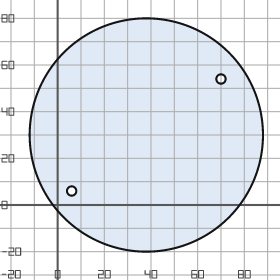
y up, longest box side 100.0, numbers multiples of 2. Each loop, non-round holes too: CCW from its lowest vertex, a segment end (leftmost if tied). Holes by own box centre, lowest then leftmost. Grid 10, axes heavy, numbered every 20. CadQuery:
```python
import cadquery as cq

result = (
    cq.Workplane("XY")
    .moveTo(38.0, 30.0)
    .circle(50.0)
    .moveTo(6.0, 6.0)
    .circle(2.0)
    .moveTo(70.0, 54.0)
    .circle(2.0)
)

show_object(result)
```